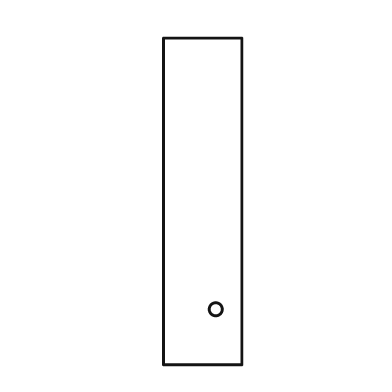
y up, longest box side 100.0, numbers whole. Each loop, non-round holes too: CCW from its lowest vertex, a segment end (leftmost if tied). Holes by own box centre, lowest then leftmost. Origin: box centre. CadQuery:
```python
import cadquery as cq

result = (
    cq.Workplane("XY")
    .moveTo(-12.0, -50.0)
    .lineTo(12.0, -50.0)
    .lineTo(12.0, 50.0)
    .lineTo(-12.0, 50.0)
    .close()
    .moveTo(4.0, -33.0)
    .circle(2.0)
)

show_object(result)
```